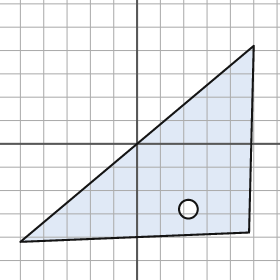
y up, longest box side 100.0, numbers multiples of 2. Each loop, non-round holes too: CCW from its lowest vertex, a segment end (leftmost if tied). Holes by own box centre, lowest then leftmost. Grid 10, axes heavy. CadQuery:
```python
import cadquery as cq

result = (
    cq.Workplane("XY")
    .moveTo(-50.0, -42.0)
    .lineTo(48.0, -38.0)
    .lineTo(50.0, 42.0)
    .close()
    .moveTo(22.0, -28.0)
    .circle(4.0)
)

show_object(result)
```